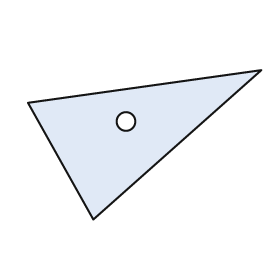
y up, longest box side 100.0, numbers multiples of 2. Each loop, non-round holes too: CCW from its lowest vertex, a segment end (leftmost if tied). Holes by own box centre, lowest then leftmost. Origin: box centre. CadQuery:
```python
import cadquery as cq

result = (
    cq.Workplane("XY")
    .moveTo(-22.0, -32.0)
    .lineTo(50.0, 32.0)
    .lineTo(-50.0, 18.0)
    .close()
    .moveTo(-8.0, 10.0)
    .circle(4.0)
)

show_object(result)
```